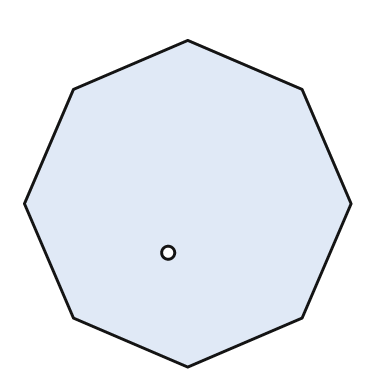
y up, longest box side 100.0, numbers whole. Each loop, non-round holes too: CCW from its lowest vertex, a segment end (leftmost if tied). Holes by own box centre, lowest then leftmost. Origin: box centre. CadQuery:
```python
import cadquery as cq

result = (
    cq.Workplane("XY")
    .moveTo(0.0, -50.0)
    .lineTo(35.0, -35.0)
    .lineTo(50.0, 0.0)
    .lineTo(35.0, 35.0)
    .lineTo(0.0, 50.0)
    .lineTo(-35.0, 35.0)
    .lineTo(-50.0, 0.0)
    .lineTo(-35.0, -35.0)
    .close()
    .moveTo(-6.0, -15.0)
    .circle(2.0)
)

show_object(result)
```